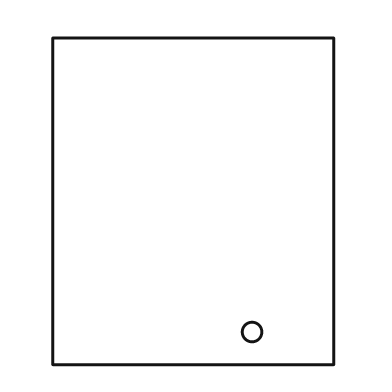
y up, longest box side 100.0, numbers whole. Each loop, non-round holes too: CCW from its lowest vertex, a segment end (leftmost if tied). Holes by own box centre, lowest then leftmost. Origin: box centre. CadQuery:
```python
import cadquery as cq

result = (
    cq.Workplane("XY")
    .moveTo(-43.0, -50.0)
    .lineTo(43.0, -50.0)
    .lineTo(43.0, 50.0)
    .lineTo(-43.0, 50.0)
    .close()
    .moveTo(18.0, -40.0)
    .circle(3.0)
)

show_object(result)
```